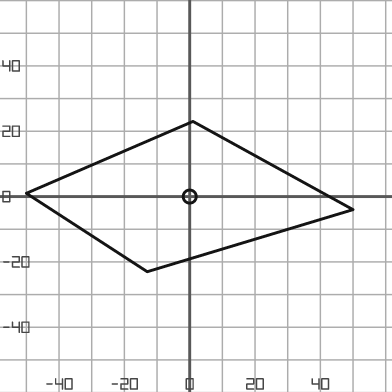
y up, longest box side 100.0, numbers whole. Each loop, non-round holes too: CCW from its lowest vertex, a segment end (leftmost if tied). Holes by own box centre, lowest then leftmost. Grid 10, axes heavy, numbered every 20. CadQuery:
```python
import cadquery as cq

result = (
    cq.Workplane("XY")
    .moveTo(-13.0, -23.0)
    .lineTo(50.0, -4.0)
    .lineTo(1.0, 23.0)
    .lineTo(-50.0, 1.0)
    .close()
    .moveTo(0.0, 0.0)
    .circle(2.0)
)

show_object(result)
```